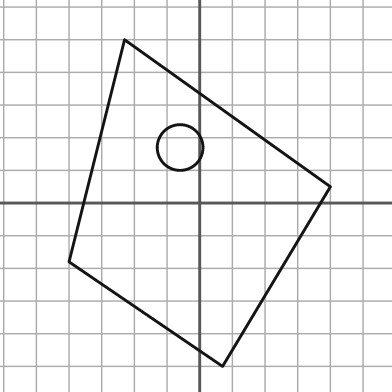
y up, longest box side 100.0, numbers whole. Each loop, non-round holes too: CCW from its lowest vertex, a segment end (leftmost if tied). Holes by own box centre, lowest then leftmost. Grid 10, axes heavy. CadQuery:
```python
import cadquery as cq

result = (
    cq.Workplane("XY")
    .moveTo(7.0, -50.0)
    .lineTo(40.0, 5.0)
    .lineTo(-23.0, 50.0)
    .lineTo(-40.0, -18.0)
    .close()
    .moveTo(-6.0, 17.0)
    .circle(7.0)
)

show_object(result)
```